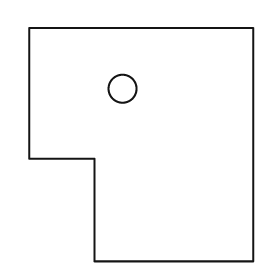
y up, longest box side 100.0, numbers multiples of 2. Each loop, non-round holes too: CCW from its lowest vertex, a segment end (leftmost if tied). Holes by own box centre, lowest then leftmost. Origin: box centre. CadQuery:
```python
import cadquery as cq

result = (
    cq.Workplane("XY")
    .moveTo(-20.0, -50.0)
    .lineTo(48.0, -50.0)
    .lineTo(48.0, 50.0)
    .lineTo(-48.0, 50.0)
    .lineTo(-48.0, -6.0)
    .lineTo(-20.0, -6.0)
    .close()
    .moveTo(-8.0, 24.0)
    .circle(6.0)
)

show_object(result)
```